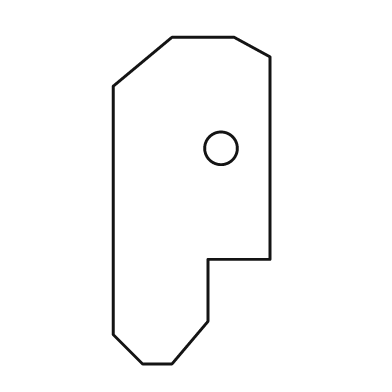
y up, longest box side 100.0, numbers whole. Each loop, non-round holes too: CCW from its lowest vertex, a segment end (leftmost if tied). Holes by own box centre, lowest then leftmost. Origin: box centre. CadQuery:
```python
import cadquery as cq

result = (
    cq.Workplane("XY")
    .moveTo(-15.0, -50.0)
    .lineTo(-6.0, -50.0)
    .lineTo(5.0, -37.0)
    .lineTo(5.0, -18.0)
    .lineTo(24.0, -18.0)
    .lineTo(24.0, 44.0)
    .lineTo(13.0, 50.0)
    .lineTo(-6.0, 50.0)
    .lineTo(-24.0, 35.0)
    .lineTo(-24.0, -41.0)
    .close()
    .moveTo(9.0, 16.0)
    .circle(5.0)
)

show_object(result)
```